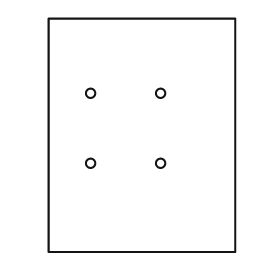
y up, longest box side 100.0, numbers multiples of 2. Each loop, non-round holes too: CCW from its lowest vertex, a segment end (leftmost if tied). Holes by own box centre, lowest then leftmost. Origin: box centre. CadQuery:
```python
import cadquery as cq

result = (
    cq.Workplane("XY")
    .moveTo(-40.0, -50.0)
    .lineTo(40.0, -50.0)
    .lineTo(40.0, 50.0)
    .lineTo(-40.0, 50.0)
    .close()
    .moveTo(-22.0, -12.0)
    .circle(2.0)
    .moveTo(8.0, -12.0)
    .circle(2.0)
    .moveTo(-22.0, 18.0)
    .circle(2.0)
    .moveTo(8.0, 18.0)
    .circle(2.0)
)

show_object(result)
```